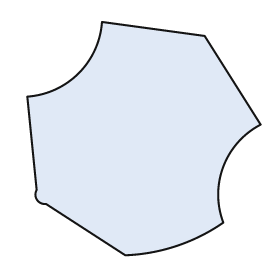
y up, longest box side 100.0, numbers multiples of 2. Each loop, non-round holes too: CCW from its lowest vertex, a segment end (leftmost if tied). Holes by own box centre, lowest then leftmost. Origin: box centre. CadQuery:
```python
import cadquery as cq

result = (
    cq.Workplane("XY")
    .moveTo(-8.0, -50.0)
    .threePointArc((14.0, -46.0), (34.0, -36.0))
    .threePointArc((34.0, -12.0), (50.0, 6.0))
    .lineTo(26.0, 44.0)
    .lineTo(-18.0, 50.0)
    .threePointArc((-28.0, 28.0), (-50.0, 18.0))
    .lineTo(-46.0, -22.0)
    .threePointArc((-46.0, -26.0), (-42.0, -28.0))
    .close()
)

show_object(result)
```